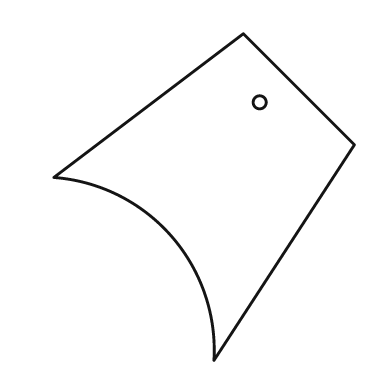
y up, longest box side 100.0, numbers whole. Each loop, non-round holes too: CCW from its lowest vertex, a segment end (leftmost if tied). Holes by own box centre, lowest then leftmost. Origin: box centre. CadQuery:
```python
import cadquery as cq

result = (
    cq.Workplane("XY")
    .moveTo(3.0, -50.0)
    .lineTo(46.0, 16.0)
    .lineTo(12.0, 50.0)
    .lineTo(-46.0, 6.0)
    .threePointArc((-10.0, -12.0), (3.0, -50.0))
    .close()
    .moveTo(17.0, 29.0)
    .circle(2.0)
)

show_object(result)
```